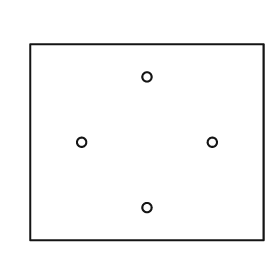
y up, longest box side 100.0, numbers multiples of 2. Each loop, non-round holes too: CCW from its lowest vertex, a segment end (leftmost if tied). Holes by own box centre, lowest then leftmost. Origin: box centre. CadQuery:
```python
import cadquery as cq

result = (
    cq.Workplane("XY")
    .moveTo(-50.0, -42.0)
    .lineTo(50.0, -42.0)
    .lineTo(50.0, 42.0)
    .lineTo(-50.0, 42.0)
    .close()
    .moveTo(0.0, -28.0)
    .circle(2.0)
    .moveTo(-28.0, 0.0)
    .circle(2.0)
    .moveTo(28.0, 0.0)
    .circle(2.0)
    .moveTo(0.0, 28.0)
    .circle(2.0)
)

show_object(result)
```